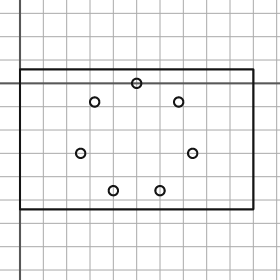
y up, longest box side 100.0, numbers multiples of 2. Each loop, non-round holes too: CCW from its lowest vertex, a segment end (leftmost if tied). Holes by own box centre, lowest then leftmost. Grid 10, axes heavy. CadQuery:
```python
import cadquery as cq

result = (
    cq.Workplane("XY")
    .moveTo(0.0, -54.0)
    .lineTo(100.0, -54.0)
    .lineTo(100.0, 6.0)
    .lineTo(0.0, 6.0)
    .close()
    .moveTo(40.0, -46.0)
    .circle(2.0)
    .moveTo(60.0, -46.0)
    .circle(2.0)
    .moveTo(26.0, -30.0)
    .circle(2.0)
    .moveTo(74.0, -30.0)
    .circle(2.0)
    .moveTo(32.0, -8.0)
    .circle(2.0)
    .moveTo(68.0, -8.0)
    .circle(2.0)
    .moveTo(50.0, 0.0)
    .circle(2.0)
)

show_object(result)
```